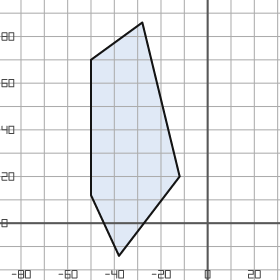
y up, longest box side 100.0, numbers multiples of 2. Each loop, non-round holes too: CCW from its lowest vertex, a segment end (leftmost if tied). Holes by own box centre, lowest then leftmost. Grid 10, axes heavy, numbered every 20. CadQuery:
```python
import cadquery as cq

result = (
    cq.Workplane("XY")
    .moveTo(-38.0, -14.0)
    .lineTo(-12.0, 20.0)
    .lineTo(-28.0, 86.0)
    .lineTo(-50.0, 70.0)
    .lineTo(-50.0, 12.0)
    .close()
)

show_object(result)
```